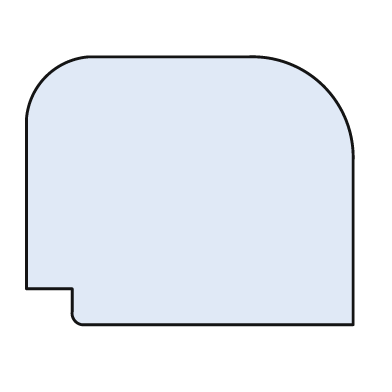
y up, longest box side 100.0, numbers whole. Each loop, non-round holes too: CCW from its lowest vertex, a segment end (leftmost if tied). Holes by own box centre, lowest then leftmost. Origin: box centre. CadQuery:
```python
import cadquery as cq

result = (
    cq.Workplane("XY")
    .moveTo(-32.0, -41.0)
    .lineTo(50.0, -41.0)
    .lineTo(50.0, 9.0)
    .threePointArc((41.0, 32.0), (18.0, 41.0))
    .lineTo(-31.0, 41.0)
    .threePointArc((-44.0, 35.0), (-50.0, 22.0))
    .lineTo(-50.0, -30.0)
    .lineTo(-36.0, -30.0)
    .lineTo(-36.0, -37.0)
    .threePointArc((-35.0, -40.0), (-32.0, -41.0))
    .close()
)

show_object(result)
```